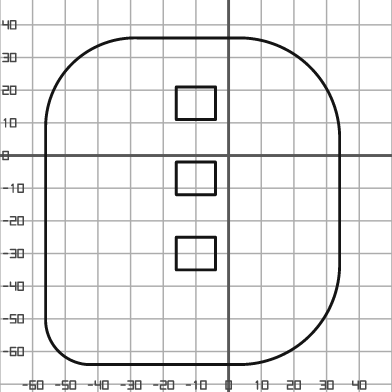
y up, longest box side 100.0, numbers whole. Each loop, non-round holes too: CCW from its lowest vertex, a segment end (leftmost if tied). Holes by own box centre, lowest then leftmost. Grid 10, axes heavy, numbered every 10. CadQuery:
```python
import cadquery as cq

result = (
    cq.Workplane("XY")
    .moveTo(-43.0, -64.0)
    .lineTo(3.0, -64.0)
    .threePointArc((25.0, -55.0), (34.0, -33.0))
    .lineTo(34.0, 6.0)
    .threePointArc((25.0, 27.0), (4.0, 36.0))
    .lineTo(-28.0, 36.0)
    .threePointArc((-48.0, 28.0), (-56.0, 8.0))
    .lineTo(-56.0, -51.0)
    .threePointArc((-52.0, -60.0), (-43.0, -64.0))
    .close()
    .moveTo(-16.0, -35.0)
    .lineTo(-4.0, -35.0)
    .lineTo(-4.0, -25.0)
    .lineTo(-16.0, -25.0)
    .close()
    .moveTo(-16.0, -12.0)
    .lineTo(-4.0, -12.0)
    .lineTo(-4.0, -2.0)
    .lineTo(-16.0, -2.0)
    .close()
    .moveTo(-16.0, 11.0)
    .lineTo(-4.0, 11.0)
    .lineTo(-4.0, 21.0)
    .lineTo(-16.0, 21.0)
    .close()
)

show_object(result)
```